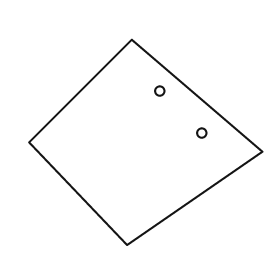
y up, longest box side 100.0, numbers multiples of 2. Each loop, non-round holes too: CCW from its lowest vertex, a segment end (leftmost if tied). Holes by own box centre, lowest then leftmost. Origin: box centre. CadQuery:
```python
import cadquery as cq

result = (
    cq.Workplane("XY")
    .moveTo(-8.0, -44.0)
    .lineTo(50.0, -4.0)
    .lineTo(-6.0, 44.0)
    .lineTo(-50.0, 0.0)
    .close()
    .moveTo(24.0, 4.0)
    .circle(2.0)
    .moveTo(6.0, 22.0)
    .circle(2.0)
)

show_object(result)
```